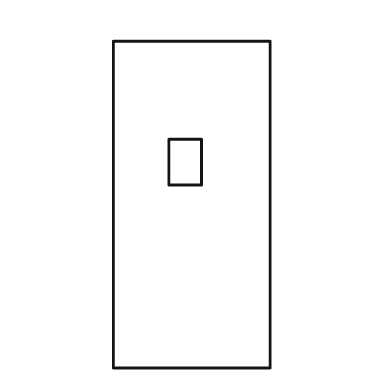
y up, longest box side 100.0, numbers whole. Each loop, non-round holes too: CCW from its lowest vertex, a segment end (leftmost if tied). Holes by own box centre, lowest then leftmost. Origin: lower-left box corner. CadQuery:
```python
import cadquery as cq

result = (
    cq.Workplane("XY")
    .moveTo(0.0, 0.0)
    .lineTo(48.0, 0.0)
    .lineTo(48.0, 100.0)
    .lineTo(0.0, 100.0)
    .close()
    .moveTo(17.0, 56.0)
    .lineTo(27.0, 56.0)
    .lineTo(27.0, 70.0)
    .lineTo(17.0, 70.0)
    .close()
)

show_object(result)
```